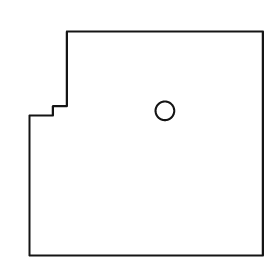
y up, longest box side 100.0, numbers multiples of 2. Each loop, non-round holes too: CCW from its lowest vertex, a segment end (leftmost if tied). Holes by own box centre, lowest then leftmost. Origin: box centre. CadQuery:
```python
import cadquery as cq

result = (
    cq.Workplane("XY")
    .moveTo(-50.0, -48.0)
    .lineTo(50.0, -48.0)
    .lineTo(50.0, 48.0)
    .lineTo(-34.0, 48.0)
    .lineTo(-34.0, 16.0)
    .lineTo(-40.0, 16.0)
    .lineTo(-40.0, 12.0)
    .lineTo(-50.0, 12.0)
    .close()
    .moveTo(8.0, 14.0)
    .circle(4.0)
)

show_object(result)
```